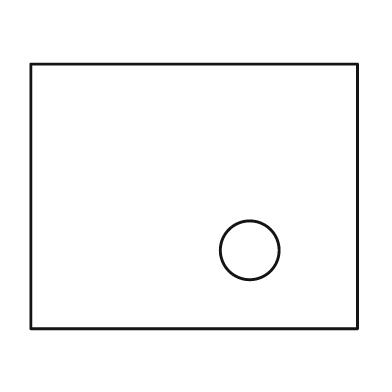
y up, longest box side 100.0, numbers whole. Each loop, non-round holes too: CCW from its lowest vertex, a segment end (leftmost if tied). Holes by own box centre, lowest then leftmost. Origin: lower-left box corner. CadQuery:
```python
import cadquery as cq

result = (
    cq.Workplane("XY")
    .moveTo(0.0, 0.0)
    .lineTo(100.0, 0.0)
    .lineTo(100.0, 81.0)
    .lineTo(0.0, 81.0)
    .close()
    .moveTo(67.0, 24.0)
    .circle(9.0)
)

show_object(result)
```